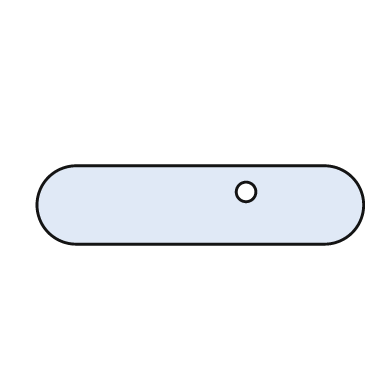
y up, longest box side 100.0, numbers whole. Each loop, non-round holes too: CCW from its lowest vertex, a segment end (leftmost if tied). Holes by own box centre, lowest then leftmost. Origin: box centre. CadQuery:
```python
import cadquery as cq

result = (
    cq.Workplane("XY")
    .moveTo(-38.0, -12.0)
    .lineTo(38.0, -12.0)
    .threePointArc((50.0, 0.0), (38.0, 12.0))
    .lineTo(-38.0, 12.0)
    .threePointArc((-50.0, 0.0), (-38.0, -12.0))
    .close()
    .moveTo(14.0, 4.0)
    .circle(3.0)
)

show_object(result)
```